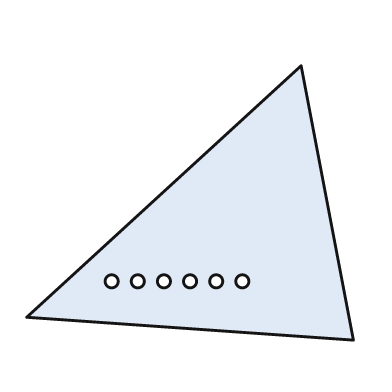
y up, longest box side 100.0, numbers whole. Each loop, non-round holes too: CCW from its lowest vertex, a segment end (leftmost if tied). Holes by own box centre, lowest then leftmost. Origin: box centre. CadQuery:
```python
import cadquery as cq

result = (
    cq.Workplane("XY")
    .moveTo(50.0, -42.0)
    .lineTo(34.0, 42.0)
    .lineTo(-50.0, -35.0)
    .close()
    .moveTo(-24.0, -24.0)
    .circle(2.0)
    .moveTo(-16.0, -24.0)
    .circle(2.0)
    .moveTo(-8.0, -24.0)
    .circle(2.0)
    .moveTo(0.0, -24.0)
    .circle(2.0)
    .moveTo(8.0, -24.0)
    .circle(2.0)
    .moveTo(16.0, -24.0)
    .circle(2.0)
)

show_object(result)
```